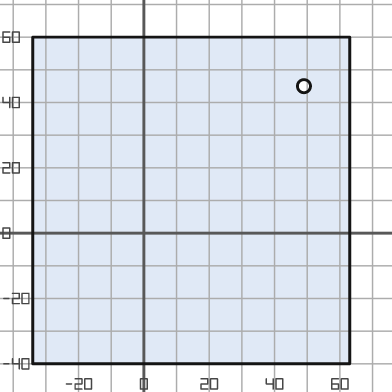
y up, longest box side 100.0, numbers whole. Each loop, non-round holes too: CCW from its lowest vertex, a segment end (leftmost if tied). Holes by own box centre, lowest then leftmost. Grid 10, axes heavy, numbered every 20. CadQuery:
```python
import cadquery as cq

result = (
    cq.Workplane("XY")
    .moveTo(-34.0, -40.0)
    .lineTo(63.0, -40.0)
    .lineTo(63.0, 60.0)
    .lineTo(-34.0, 60.0)
    .close()
    .moveTo(49.0, 45.0)
    .circle(2.0)
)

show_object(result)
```